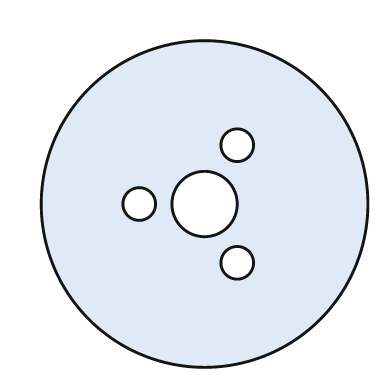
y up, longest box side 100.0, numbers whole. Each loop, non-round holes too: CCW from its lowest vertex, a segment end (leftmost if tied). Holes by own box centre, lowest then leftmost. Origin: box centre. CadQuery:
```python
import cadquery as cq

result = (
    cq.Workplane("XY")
    .moveTo(0.0, 0.0)
    .circle(50.0)
    .moveTo(10.0, -18.0)
    .circle(5.0)
    .moveTo(-20.0, 0.0)
    .circle(5.0)
    .moveTo(0.0, 0.0)
    .circle(10.0)
    .moveTo(10.0, 18.0)
    .circle(5.0)
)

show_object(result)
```